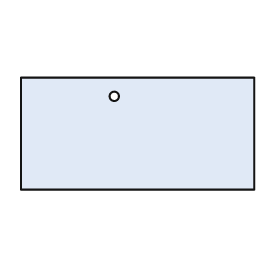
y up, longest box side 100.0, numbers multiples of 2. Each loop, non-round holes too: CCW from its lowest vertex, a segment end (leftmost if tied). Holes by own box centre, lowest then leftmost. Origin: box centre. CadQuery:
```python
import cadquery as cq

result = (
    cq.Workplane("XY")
    .moveTo(-50.0, -24.0)
    .lineTo(50.0, -24.0)
    .lineTo(50.0, 24.0)
    .lineTo(-50.0, 24.0)
    .close()
    .moveTo(-10.0, 16.0)
    .circle(2.0)
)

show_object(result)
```